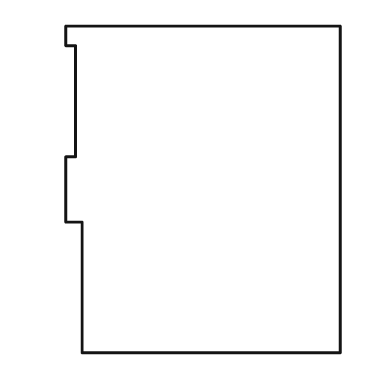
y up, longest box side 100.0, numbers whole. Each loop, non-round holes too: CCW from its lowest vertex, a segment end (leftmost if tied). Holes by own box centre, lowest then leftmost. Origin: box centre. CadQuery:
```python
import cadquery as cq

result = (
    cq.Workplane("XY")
    .moveTo(-37.0, -50.0)
    .lineTo(42.0, -50.0)
    .lineTo(42.0, 50.0)
    .lineTo(-42.0, 50.0)
    .lineTo(-42.0, 44.0)
    .lineTo(-39.0, 44.0)
    .lineTo(-39.0, 10.0)
    .lineTo(-42.0, 10.0)
    .lineTo(-42.0, -10.0)
    .lineTo(-37.0, -10.0)
    .close()
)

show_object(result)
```